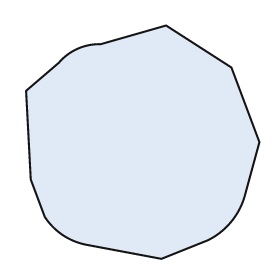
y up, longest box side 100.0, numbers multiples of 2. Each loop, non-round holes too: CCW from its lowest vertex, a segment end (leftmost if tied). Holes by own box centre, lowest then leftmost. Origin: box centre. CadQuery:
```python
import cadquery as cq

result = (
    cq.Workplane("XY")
    .moveTo(8.0, -50.0)
    .lineTo(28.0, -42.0)
    .threePointArc((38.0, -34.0), (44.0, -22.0))
    .lineTo(50.0, 0.0)
    .lineTo(38.0, 32.0)
    .lineTo(10.0, 50.0)
    .lineTo(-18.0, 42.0)
    .threePointArc((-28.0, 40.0), (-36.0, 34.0))
    .lineTo(-50.0, 22.0)
    .lineTo(-48.0, -16.0)
    .lineTo(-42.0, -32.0)
    .threePointArc((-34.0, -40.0), (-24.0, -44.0))
    .close()
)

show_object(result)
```